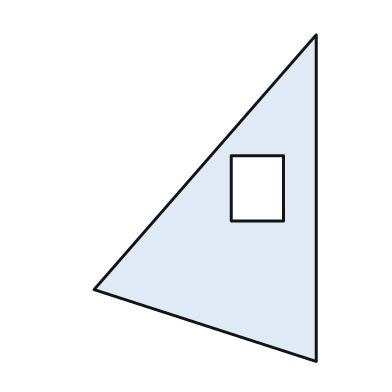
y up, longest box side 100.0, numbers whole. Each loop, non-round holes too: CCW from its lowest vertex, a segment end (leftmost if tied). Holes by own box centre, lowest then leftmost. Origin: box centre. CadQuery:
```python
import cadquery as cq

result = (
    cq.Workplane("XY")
    .moveTo(34.0, -50.0)
    .lineTo(34.0, 50.0)
    .lineTo(-34.0, -28.0)
    .close()
    .moveTo(8.0, -7.0)
    .lineTo(24.0, -7.0)
    .lineTo(24.0, 13.0)
    .lineTo(8.0, 13.0)
    .close()
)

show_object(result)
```